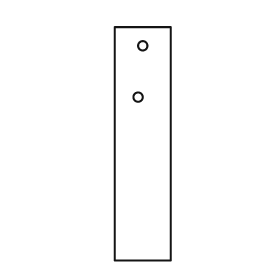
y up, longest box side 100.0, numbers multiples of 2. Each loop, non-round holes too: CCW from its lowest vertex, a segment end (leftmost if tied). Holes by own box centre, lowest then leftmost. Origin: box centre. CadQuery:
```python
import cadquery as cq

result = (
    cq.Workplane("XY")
    .moveTo(-12.0, -50.0)
    .lineTo(12.0, -50.0)
    .lineTo(12.0, 50.0)
    .lineTo(-12.0, 50.0)
    .close()
    .moveTo(-2.0, 20.0)
    .circle(2.0)
    .moveTo(0.0, 42.0)
    .circle(2.0)
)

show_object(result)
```